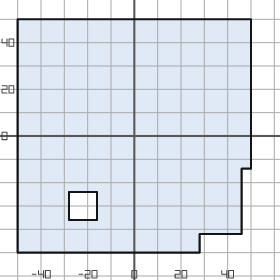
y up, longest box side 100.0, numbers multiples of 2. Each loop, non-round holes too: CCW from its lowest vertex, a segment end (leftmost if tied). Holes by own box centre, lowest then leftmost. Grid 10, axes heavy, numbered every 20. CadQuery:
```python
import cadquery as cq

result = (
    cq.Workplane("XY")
    .moveTo(-50.0, -50.0)
    .lineTo(28.0, -50.0)
    .lineTo(28.0, -42.0)
    .lineTo(46.0, -42.0)
    .lineTo(46.0, -14.0)
    .lineTo(50.0, -14.0)
    .lineTo(50.0, 50.0)
    .lineTo(-50.0, 50.0)
    .close()
    .moveTo(-28.0, -36.0)
    .lineTo(-16.0, -36.0)
    .lineTo(-16.0, -24.0)
    .lineTo(-28.0, -24.0)
    .close()
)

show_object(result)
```